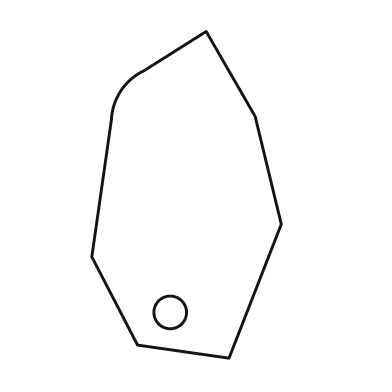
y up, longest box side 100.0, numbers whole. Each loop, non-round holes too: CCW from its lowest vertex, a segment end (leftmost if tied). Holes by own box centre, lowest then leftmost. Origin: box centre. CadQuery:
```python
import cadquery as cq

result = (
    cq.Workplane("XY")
    .moveTo(13.0, -50.0)
    .lineTo(29.0, -9.0)
    .lineTo(21.0, 24.0)
    .lineTo(6.0, 50.0)
    .lineTo(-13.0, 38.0)
    .threePointArc((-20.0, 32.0), (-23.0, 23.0))
    .lineTo(-29.0, -19.0)
    .lineTo(-15.0, -46.0)
    .close()
    .moveTo(-5.0, -36.0)
    .circle(5.0)
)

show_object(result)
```